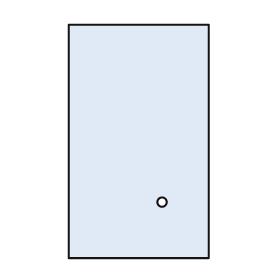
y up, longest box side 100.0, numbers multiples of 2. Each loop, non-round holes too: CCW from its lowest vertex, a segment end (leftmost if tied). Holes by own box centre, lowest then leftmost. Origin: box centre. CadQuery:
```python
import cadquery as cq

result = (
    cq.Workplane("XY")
    .moveTo(-30.0, -50.0)
    .lineTo(30.0, -50.0)
    .lineTo(30.0, 50.0)
    .lineTo(-30.0, 50.0)
    .close()
    .moveTo(10.0, -26.0)
    .circle(2.0)
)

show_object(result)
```